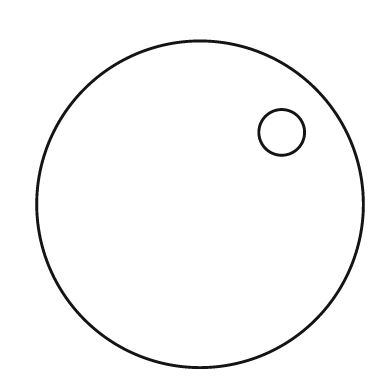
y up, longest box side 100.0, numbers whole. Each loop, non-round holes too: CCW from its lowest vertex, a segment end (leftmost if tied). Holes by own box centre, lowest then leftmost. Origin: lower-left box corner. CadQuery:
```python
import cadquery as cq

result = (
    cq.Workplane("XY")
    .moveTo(50.0, 50.0)
    .circle(50.0)
    .moveTo(75.0, 72.0)
    .circle(7.0)
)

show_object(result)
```